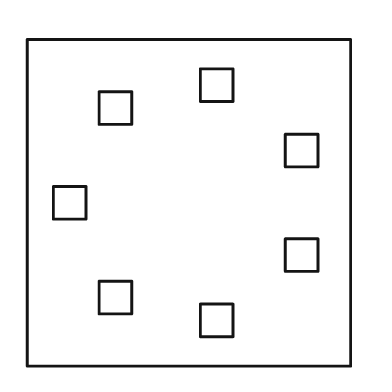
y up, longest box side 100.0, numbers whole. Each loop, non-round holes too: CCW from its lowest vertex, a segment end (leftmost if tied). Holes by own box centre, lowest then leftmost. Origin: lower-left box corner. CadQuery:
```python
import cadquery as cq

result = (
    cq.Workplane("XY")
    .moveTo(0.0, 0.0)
    .lineTo(99.0, 0.0)
    .lineTo(99.0, 100.0)
    .lineTo(0.0, 100.0)
    .close()
    .moveTo(53.0, 9.0)
    .lineTo(63.0, 9.0)
    .lineTo(63.0, 19.0)
    .lineTo(53.0, 19.0)
    .close()
    .moveTo(22.0, 16.0)
    .lineTo(32.0, 16.0)
    .lineTo(32.0, 26.0)
    .lineTo(22.0, 26.0)
    .close()
    .moveTo(79.0, 29.0)
    .lineTo(89.0, 29.0)
    .lineTo(89.0, 39.0)
    .lineTo(79.0, 39.0)
    .close()
    .moveTo(8.0, 45.0)
    .lineTo(18.0, 45.0)
    .lineTo(18.0, 55.0)
    .lineTo(8.0, 55.0)
    .close()
    .moveTo(79.0, 61.0)
    .lineTo(89.0, 61.0)
    .lineTo(89.0, 71.0)
    .lineTo(79.0, 71.0)
    .close()
    .moveTo(22.0, 74.0)
    .lineTo(32.0, 74.0)
    .lineTo(32.0, 84.0)
    .lineTo(22.0, 84.0)
    .close()
    .moveTo(53.0, 81.0)
    .lineTo(63.0, 81.0)
    .lineTo(63.0, 91.0)
    .lineTo(53.0, 91.0)
    .close()
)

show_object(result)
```